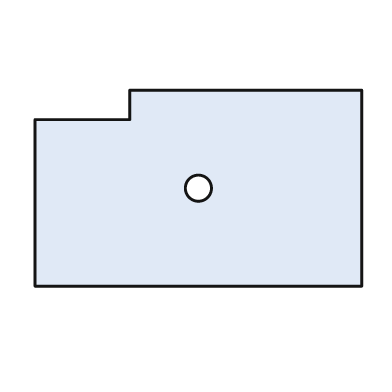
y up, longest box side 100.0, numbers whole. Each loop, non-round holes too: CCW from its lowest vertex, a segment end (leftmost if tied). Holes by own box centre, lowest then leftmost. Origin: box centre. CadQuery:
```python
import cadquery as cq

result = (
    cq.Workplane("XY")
    .moveTo(-50.0, -30.0)
    .lineTo(50.0, -30.0)
    .lineTo(50.0, 30.0)
    .lineTo(-21.0, 30.0)
    .lineTo(-21.0, 21.0)
    .lineTo(-50.0, 21.0)
    .close()
    .moveTo(0.0, 0.0)
    .circle(4.0)
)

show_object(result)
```